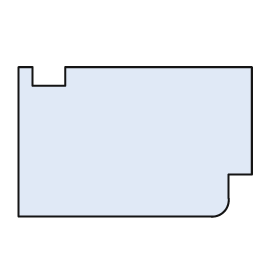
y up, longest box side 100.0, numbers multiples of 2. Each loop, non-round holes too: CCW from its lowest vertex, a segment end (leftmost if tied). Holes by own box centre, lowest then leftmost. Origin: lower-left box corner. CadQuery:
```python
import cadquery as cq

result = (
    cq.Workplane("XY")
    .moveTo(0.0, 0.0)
    .lineTo(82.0, 0.0)
    .threePointArc((88.0, 2.0), (90.0, 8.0))
    .lineTo(90.0, 18.0)
    .lineTo(100.0, 18.0)
    .lineTo(100.0, 64.0)
    .lineTo(20.0, 64.0)
    .lineTo(20.0, 56.0)
    .lineTo(6.0, 56.0)
    .lineTo(6.0, 64.0)
    .lineTo(0.0, 64.0)
    .close()
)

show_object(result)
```